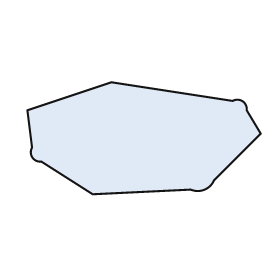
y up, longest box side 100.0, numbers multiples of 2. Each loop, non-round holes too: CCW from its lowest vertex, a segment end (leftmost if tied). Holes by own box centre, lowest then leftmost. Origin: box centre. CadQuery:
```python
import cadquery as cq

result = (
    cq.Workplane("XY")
    .moveTo(-22.0, -24.0)
    .lineTo(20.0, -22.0)
    .threePointArc((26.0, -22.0), (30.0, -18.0))
    .lineTo(50.0, 2.0)
    .lineTo(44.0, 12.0)
    .threePointArc((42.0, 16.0), (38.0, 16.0))
    .lineTo(-14.0, 24.0)
    .lineTo(-50.0, 12.0)
    .lineTo(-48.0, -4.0)
    .threePointArc((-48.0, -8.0), (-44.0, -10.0))
    .close()
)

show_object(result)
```